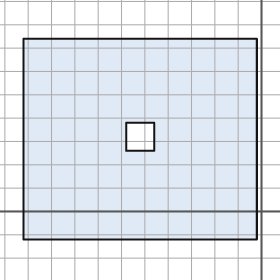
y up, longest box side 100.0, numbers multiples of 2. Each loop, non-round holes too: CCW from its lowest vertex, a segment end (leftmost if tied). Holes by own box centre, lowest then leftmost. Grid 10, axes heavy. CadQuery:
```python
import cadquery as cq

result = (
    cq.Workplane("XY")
    .moveTo(-102.0, -12.0)
    .lineTo(-2.0, -12.0)
    .lineTo(-2.0, 74.0)
    .lineTo(-102.0, 74.0)
    .close()
    .moveTo(-58.0, 26.0)
    .lineTo(-46.0, 26.0)
    .lineTo(-46.0, 38.0)
    .lineTo(-58.0, 38.0)
    .close()
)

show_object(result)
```